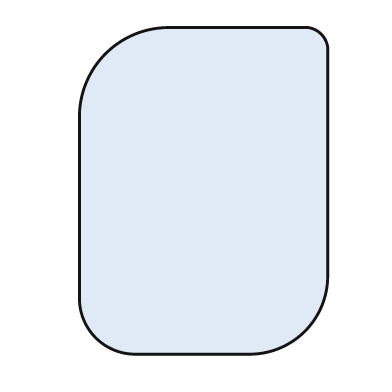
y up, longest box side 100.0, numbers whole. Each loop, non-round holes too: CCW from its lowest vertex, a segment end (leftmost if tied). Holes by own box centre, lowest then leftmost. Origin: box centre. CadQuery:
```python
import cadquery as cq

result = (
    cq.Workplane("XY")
    .moveTo(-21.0, -50.0)
    .lineTo(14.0, -50.0)
    .threePointArc((31.0, -43.0), (38.0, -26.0))
    .lineTo(38.0, 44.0)
    .threePointArc((36.0, 48.0), (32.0, 50.0))
    .lineTo(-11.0, 50.0)
    .threePointArc((-30.0, 42.0), (-38.0, 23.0))
    .lineTo(-38.0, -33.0)
    .threePointArc((-33.0, -45.0), (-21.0, -50.0))
    .close()
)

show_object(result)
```